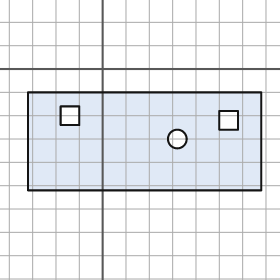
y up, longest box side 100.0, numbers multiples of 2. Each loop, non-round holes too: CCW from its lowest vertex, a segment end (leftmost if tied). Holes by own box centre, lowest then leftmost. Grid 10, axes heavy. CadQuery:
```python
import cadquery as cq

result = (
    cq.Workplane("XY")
    .moveTo(-32.0, -52.0)
    .lineTo(68.0, -52.0)
    .lineTo(68.0, -10.0)
    .lineTo(-32.0, -10.0)
    .close()
    .moveTo(32.0, -30.0)
    .circle(4.0)
    .moveTo(50.0, -26.0)
    .lineTo(58.0, -26.0)
    .lineTo(58.0, -18.0)
    .lineTo(50.0, -18.0)
    .close()
    .moveTo(-18.0, -24.0)
    .lineTo(-10.0, -24.0)
    .lineTo(-10.0, -16.0)
    .lineTo(-18.0, -16.0)
    .close()
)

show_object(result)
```